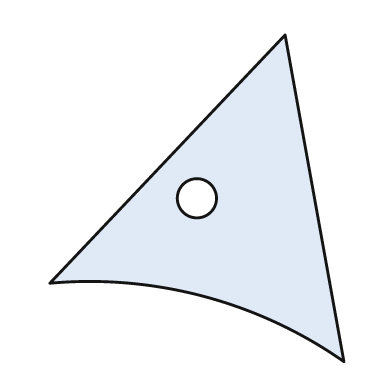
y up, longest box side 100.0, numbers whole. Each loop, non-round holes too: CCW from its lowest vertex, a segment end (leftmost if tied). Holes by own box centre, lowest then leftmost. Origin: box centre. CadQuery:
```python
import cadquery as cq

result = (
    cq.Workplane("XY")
    .moveTo(45.0, -50.0)
    .lineTo(27.0, 50.0)
    .lineTo(-45.0, -26.0)
    .threePointArc((2.0, -30.0), (45.0, -50.0))
    .close()
    .moveTo(0.0, 0.0)
    .circle(6.0)
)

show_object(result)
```